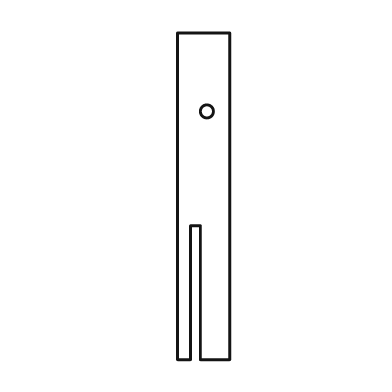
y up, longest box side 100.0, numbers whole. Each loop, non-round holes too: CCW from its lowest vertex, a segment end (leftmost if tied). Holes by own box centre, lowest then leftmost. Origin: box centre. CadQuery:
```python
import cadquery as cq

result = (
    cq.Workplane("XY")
    .moveTo(-8.0, -50.0)
    .lineTo(-4.0, -50.0)
    .lineTo(-4.0, -9.0)
    .lineTo(-1.0, -9.0)
    .lineTo(-1.0, -50.0)
    .lineTo(8.0, -50.0)
    .lineTo(8.0, 50.0)
    .lineTo(-8.0, 50.0)
    .close()
    .moveTo(1.0, 26.0)
    .circle(2.0)
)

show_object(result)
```